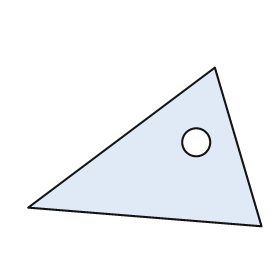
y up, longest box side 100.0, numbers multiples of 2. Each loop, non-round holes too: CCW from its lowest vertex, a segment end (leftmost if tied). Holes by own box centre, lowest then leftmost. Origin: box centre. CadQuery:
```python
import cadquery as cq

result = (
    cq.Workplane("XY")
    .moveTo(50.0, -34.0)
    .lineTo(30.0, 34.0)
    .lineTo(-50.0, -26.0)
    .close()
    .moveTo(22.0, 2.0)
    .circle(6.0)
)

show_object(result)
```